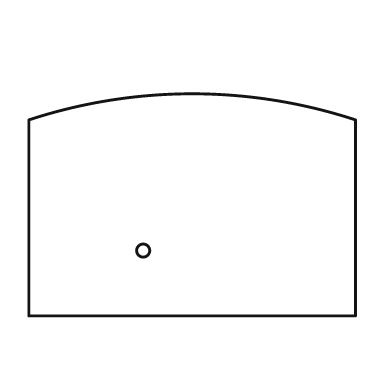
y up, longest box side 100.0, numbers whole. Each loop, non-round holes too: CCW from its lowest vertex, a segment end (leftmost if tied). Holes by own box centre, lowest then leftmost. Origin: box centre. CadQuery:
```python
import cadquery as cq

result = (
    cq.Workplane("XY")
    .moveTo(-50.0, -34.0)
    .lineTo(50.0, -34.0)
    .lineTo(50.0, 26.0)
    .threePointArc((0.0, 34.0), (-50.0, 26.0))
    .close()
    .moveTo(-15.0, -14.0)
    .circle(2.0)
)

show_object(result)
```